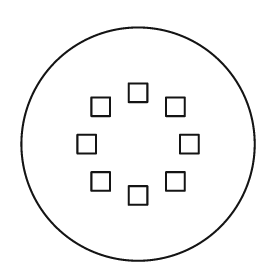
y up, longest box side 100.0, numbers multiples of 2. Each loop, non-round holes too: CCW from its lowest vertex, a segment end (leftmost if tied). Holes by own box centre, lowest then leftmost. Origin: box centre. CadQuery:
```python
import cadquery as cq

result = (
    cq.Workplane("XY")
    .moveTo(0.0, 0.0)
    .circle(50.0)
    .moveTo(-4.0, -26.0)
    .lineTo(4.0, -26.0)
    .lineTo(4.0, -18.0)
    .lineTo(-4.0, -18.0)
    .close()
    .moveTo(-20.0, -20.0)
    .lineTo(-12.0, -20.0)
    .lineTo(-12.0, -12.0)
    .lineTo(-20.0, -12.0)
    .close()
    .moveTo(12.0, -20.0)
    .lineTo(20.0, -20.0)
    .lineTo(20.0, -12.0)
    .lineTo(12.0, -12.0)
    .close()
    .moveTo(-26.0, -4.0)
    .lineTo(-18.0, -4.0)
    .lineTo(-18.0, 4.0)
    .lineTo(-26.0, 4.0)
    .close()
    .moveTo(18.0, -4.0)
    .lineTo(26.0, -4.0)
    .lineTo(26.0, 4.0)
    .lineTo(18.0, 4.0)
    .close()
    .moveTo(-20.0, 12.0)
    .lineTo(-12.0, 12.0)
    .lineTo(-12.0, 20.0)
    .lineTo(-20.0, 20.0)
    .close()
    .moveTo(12.0, 12.0)
    .lineTo(20.0, 12.0)
    .lineTo(20.0, 20.0)
    .lineTo(12.0, 20.0)
    .close()
    .moveTo(-4.0, 18.0)
    .lineTo(4.0, 18.0)
    .lineTo(4.0, 26.0)
    .lineTo(-4.0, 26.0)
    .close()
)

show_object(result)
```